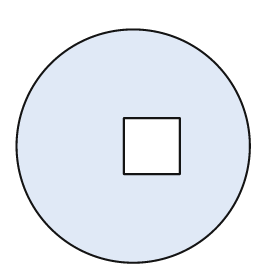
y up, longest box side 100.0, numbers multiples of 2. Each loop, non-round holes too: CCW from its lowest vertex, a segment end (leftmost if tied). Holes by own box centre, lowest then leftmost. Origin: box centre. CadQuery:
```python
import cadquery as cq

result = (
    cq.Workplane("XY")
    .moveTo(0.0, 0.0)
    .circle(50.0)
    .moveTo(-4.0, -12.0)
    .lineTo(20.0, -12.0)
    .lineTo(20.0, 12.0)
    .lineTo(-4.0, 12.0)
    .close()
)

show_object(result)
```